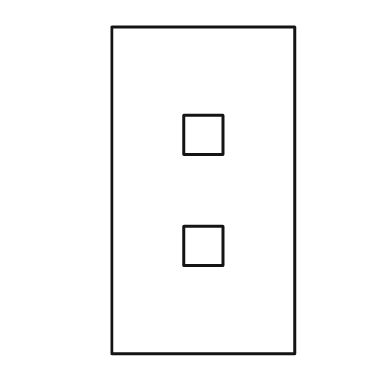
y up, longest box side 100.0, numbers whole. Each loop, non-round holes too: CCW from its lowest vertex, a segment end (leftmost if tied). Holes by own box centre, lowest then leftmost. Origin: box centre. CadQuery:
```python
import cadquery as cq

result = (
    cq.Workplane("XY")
    .moveTo(-28.0, -50.0)
    .lineTo(28.0, -50.0)
    .lineTo(28.0, 50.0)
    .lineTo(-28.0, 50.0)
    .close()
    .moveTo(-6.0, -23.0)
    .lineTo(6.0, -23.0)
    .lineTo(6.0, -11.0)
    .lineTo(-6.0, -11.0)
    .close()
    .moveTo(-6.0, 11.0)
    .lineTo(6.0, 11.0)
    .lineTo(6.0, 23.0)
    .lineTo(-6.0, 23.0)
    .close()
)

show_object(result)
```